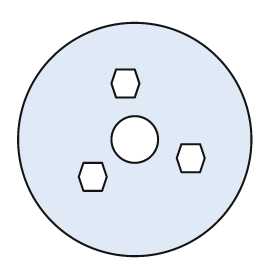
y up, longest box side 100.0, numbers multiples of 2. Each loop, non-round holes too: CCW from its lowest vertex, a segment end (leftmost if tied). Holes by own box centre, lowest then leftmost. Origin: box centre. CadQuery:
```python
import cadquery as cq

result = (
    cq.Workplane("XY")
    .moveTo(0.0, 0.0)
    .circle(50.0)
    .moveTo(-22.0, -22.0)
    .lineTo(-14.0, -22.0)
    .lineTo(-12.0, -16.0)
    .lineTo(-14.0, -10.0)
    .lineTo(-22.0, -10.0)
    .lineTo(-24.0, -16.0)
    .close()
    .moveTo(20.0, -14.0)
    .lineTo(28.0, -14.0)
    .lineTo(30.0, -8.0)
    .lineTo(28.0, -2.0)
    .lineTo(20.0, -2.0)
    .lineTo(18.0, -8.0)
    .close()
    .moveTo(0.0, 0.0)
    .circle(10.0)
    .moveTo(-8.0, 18.0)
    .lineTo(0.0, 18.0)
    .lineTo(2.0, 24.0)
    .lineTo(0.0, 30.0)
    .lineTo(-8.0, 30.0)
    .lineTo(-10.0, 24.0)
    .close()
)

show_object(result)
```